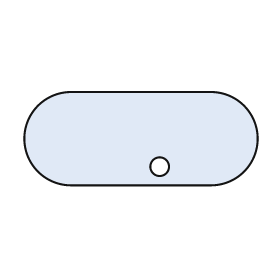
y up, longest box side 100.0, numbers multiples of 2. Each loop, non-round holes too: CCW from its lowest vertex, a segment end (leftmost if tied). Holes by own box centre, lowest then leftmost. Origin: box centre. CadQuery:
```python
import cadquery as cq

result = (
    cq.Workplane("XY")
    .moveTo(-30.0, -20.0)
    .lineTo(30.0, -20.0)
    .threePointArc((50.0, 0.0), (30.0, 20.0))
    .lineTo(-30.0, 20.0)
    .threePointArc((-50.0, 0.0), (-30.0, -20.0))
    .close()
    .moveTo(8.0, -12.0)
    .circle(4.0)
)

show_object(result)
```